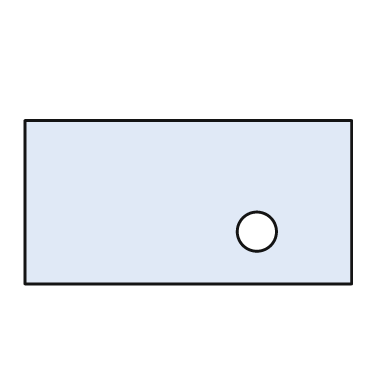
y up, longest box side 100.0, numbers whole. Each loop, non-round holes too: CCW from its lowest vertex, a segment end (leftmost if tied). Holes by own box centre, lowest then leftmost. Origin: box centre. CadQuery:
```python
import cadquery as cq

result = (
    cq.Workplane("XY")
    .moveTo(-50.0, -25.0)
    .lineTo(50.0, -25.0)
    .lineTo(50.0, 25.0)
    .lineTo(-50.0, 25.0)
    .close()
    .moveTo(21.0, -9.0)
    .circle(6.0)
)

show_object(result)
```